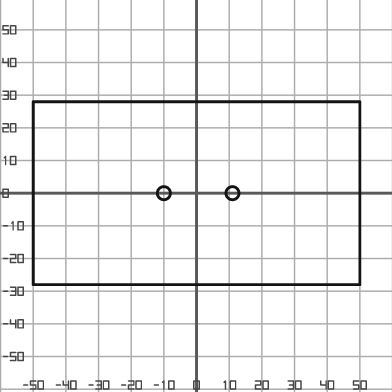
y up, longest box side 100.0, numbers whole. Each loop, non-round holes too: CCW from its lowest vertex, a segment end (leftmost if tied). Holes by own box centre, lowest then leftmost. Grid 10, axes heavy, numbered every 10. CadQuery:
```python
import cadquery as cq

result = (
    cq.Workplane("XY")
    .moveTo(-50.0, -28.0)
    .lineTo(50.0, -28.0)
    .lineTo(50.0, 28.0)
    .lineTo(-50.0, 28.0)
    .close()
    .moveTo(-10.0, 0.0)
    .circle(2.0)
    .moveTo(11.0, 0.0)
    .circle(2.0)
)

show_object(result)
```